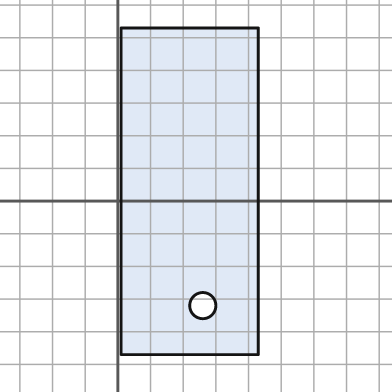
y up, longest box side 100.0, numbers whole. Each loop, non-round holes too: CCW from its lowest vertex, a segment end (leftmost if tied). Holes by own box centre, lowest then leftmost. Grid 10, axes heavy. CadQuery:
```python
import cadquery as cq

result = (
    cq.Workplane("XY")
    .moveTo(1.0, -47.0)
    .lineTo(43.0, -47.0)
    .lineTo(43.0, 53.0)
    .lineTo(1.0, 53.0)
    .close()
    .moveTo(26.0, -32.0)
    .circle(4.0)
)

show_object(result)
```